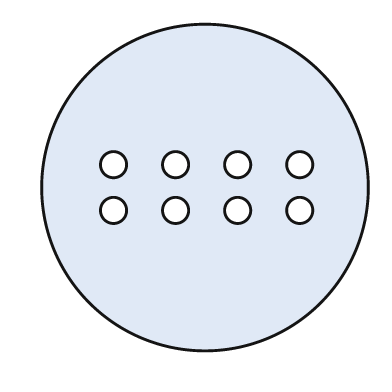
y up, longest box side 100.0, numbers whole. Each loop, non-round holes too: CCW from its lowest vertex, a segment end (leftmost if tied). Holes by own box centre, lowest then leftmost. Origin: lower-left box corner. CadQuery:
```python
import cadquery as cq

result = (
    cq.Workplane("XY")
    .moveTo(50.0, 50.0)
    .circle(50.0)
    .moveTo(22.0, 43.0)
    .circle(4.0)
    .moveTo(41.0, 43.0)
    .circle(4.0)
    .moveTo(60.0, 43.0)
    .circle(4.0)
    .moveTo(79.0, 43.0)
    .circle(4.0)
    .moveTo(22.0, 57.0)
    .circle(4.0)
    .moveTo(41.0, 57.0)
    .circle(4.0)
    .moveTo(60.0, 57.0)
    .circle(4.0)
    .moveTo(79.0, 57.0)
    .circle(4.0)
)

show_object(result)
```